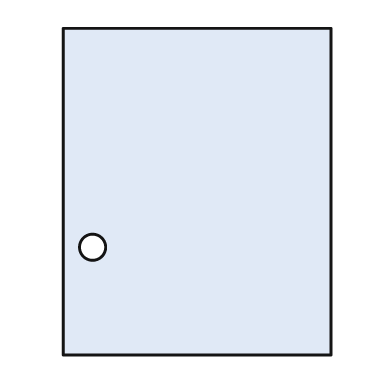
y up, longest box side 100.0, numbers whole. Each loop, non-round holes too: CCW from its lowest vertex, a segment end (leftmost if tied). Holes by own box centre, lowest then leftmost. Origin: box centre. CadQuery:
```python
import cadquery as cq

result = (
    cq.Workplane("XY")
    .moveTo(-41.0, -50.0)
    .lineTo(41.0, -50.0)
    .lineTo(41.0, 50.0)
    .lineTo(-41.0, 50.0)
    .close()
    .moveTo(-32.0, -17.0)
    .circle(4.0)
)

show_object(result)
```